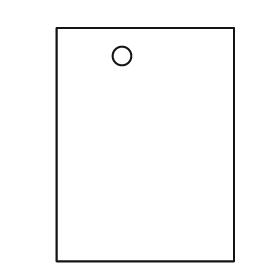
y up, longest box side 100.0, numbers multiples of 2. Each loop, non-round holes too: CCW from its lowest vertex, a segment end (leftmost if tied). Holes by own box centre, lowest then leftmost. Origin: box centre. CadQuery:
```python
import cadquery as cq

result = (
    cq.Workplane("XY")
    .moveTo(-38.0, -50.0)
    .lineTo(38.0, -50.0)
    .lineTo(38.0, 50.0)
    .lineTo(-38.0, 50.0)
    .close()
    .moveTo(-10.0, 38.0)
    .circle(4.0)
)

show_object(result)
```